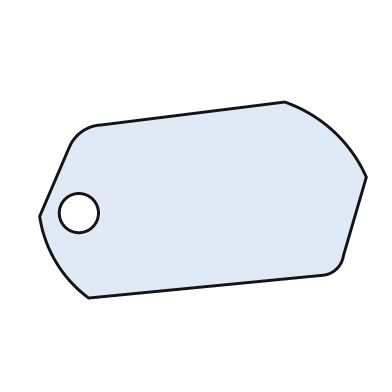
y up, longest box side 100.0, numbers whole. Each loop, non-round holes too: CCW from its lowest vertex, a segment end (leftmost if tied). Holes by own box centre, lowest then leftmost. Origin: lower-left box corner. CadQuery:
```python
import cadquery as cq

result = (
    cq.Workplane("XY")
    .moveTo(15.0, 0.0)
    .lineTo(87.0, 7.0)
    .threePointArc((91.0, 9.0), (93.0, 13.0))
    .lineTo(100.0, 37.0)
    .threePointArc((90.0, 51.0), (75.0, 60.0))
    .lineTo(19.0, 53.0)
    .threePointArc((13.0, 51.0), (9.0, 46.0))
    .lineTo(0.0, 25.0)
    .threePointArc((5.0, 11.0), (15.0, 0.0))
    .close()
    .moveTo(12.0, 26.0)
    .circle(6.0)
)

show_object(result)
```